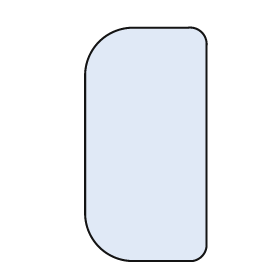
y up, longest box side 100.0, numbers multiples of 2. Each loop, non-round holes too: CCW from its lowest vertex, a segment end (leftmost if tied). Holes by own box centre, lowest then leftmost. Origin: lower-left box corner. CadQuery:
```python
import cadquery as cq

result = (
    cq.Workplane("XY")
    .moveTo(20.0, 0.0)
    .lineTo(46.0, 0.0)
    .threePointArc((50.0, 2.0), (52.0, 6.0))
    .lineTo(52.0, 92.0)
    .threePointArc((50.0, 98.0), (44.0, 100.0))
    .lineTo(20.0, 100.0)
    .threePointArc((6.0, 94.0), (0.0, 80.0))
    .lineTo(0.0, 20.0)
    .threePointArc((6.0, 6.0), (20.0, 0.0))
    .close()
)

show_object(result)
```